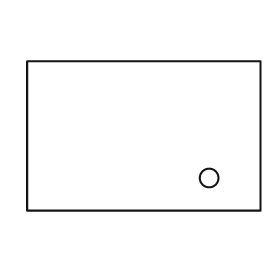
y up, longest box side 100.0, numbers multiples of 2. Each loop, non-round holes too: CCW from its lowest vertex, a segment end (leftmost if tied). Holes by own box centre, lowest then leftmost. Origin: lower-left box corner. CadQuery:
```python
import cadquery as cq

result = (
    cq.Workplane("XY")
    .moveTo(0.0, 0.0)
    .lineTo(100.0, 0.0)
    .lineTo(100.0, 64.0)
    .lineTo(0.0, 64.0)
    .close()
    .moveTo(78.0, 14.0)
    .circle(4.0)
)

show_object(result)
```